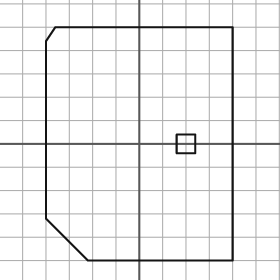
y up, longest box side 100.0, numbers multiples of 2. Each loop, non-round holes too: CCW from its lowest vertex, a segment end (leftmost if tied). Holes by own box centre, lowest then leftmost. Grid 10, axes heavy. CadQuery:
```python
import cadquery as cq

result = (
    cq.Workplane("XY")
    .moveTo(-22.0, -50.0)
    .lineTo(40.0, -50.0)
    .lineTo(40.0, 50.0)
    .lineTo(-36.0, 50.0)
    .lineTo(-40.0, 44.0)
    .lineTo(-40.0, -32.0)
    .close()
    .moveTo(16.0, -4.0)
    .lineTo(24.0, -4.0)
    .lineTo(24.0, 4.0)
    .lineTo(16.0, 4.0)
    .close()
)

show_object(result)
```